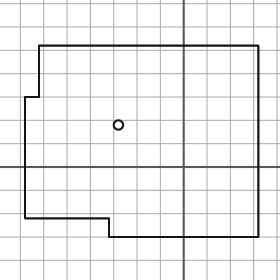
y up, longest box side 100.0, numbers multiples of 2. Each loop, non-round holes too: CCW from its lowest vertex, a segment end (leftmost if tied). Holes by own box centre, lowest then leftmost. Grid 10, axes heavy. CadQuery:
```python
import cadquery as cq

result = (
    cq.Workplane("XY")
    .moveTo(-32.0, -30.0)
    .lineTo(32.0, -30.0)
    .lineTo(32.0, 52.0)
    .lineTo(-62.0, 52.0)
    .lineTo(-62.0, 30.0)
    .lineTo(-68.0, 30.0)
    .lineTo(-68.0, -22.0)
    .lineTo(-32.0, -22.0)
    .close()
    .moveTo(-28.0, 18.0)
    .circle(2.0)
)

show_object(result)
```